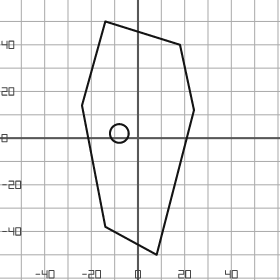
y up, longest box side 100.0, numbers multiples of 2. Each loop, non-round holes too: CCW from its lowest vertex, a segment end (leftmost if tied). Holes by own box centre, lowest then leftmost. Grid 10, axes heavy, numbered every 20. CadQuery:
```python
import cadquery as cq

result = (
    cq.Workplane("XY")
    .moveTo(8.0, -50.0)
    .lineTo(24.0, 12.0)
    .lineTo(18.0, 40.0)
    .lineTo(-14.0, 50.0)
    .lineTo(-24.0, 14.0)
    .lineTo(-14.0, -38.0)
    .close()
    .moveTo(-8.0, 2.0)
    .circle(4.0)
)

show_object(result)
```